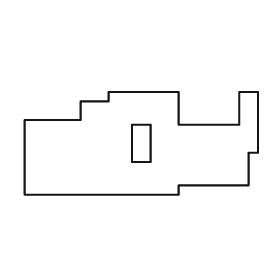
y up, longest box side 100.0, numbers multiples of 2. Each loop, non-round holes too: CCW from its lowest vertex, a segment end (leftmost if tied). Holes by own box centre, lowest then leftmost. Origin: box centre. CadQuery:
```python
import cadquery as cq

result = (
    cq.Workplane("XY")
    .moveTo(-50.0, -22.0)
    .lineTo(16.0, -22.0)
    .lineTo(16.0, -18.0)
    .lineTo(46.0, -18.0)
    .lineTo(46.0, -4.0)
    .lineTo(50.0, -4.0)
    .lineTo(50.0, 22.0)
    .lineTo(42.0, 22.0)
    .lineTo(42.0, 8.0)
    .lineTo(16.0, 8.0)
    .lineTo(16.0, 22.0)
    .lineTo(-14.0, 22.0)
    .lineTo(-14.0, 18.0)
    .lineTo(-26.0, 18.0)
    .lineTo(-26.0, 10.0)
    .lineTo(-50.0, 10.0)
    .close()
    .moveTo(-4.0, -8.0)
    .lineTo(4.0, -8.0)
    .lineTo(4.0, 8.0)
    .lineTo(-4.0, 8.0)
    .close()
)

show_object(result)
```